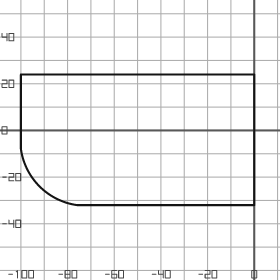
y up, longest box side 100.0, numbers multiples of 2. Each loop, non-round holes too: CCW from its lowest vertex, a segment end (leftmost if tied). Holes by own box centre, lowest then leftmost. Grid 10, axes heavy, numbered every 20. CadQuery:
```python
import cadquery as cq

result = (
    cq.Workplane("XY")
    .moveTo(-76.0, -32.0)
    .lineTo(0.0, -32.0)
    .lineTo(0.0, 24.0)
    .lineTo(-100.0, 24.0)
    .lineTo(-100.0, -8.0)
    .threePointArc((-92.0, -24.0), (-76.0, -32.0))
    .close()
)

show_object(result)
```